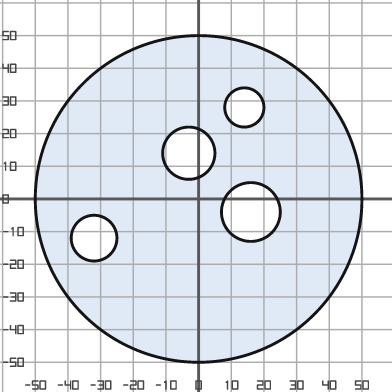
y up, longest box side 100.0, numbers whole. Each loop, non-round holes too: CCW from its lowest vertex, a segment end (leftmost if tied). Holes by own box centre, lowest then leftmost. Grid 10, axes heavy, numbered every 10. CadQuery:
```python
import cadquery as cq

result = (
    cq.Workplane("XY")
    .moveTo(0.0, 0.0)
    .circle(50.0)
    .moveTo(-32.0, -12.0)
    .circle(7.0)
    .moveTo(16.0, -4.0)
    .circle(9.0)
    .moveTo(-3.0, 14.0)
    .circle(8.0)
    .moveTo(14.0, 28.0)
    .circle(6.0)
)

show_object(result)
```